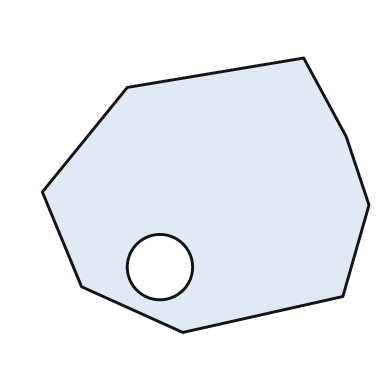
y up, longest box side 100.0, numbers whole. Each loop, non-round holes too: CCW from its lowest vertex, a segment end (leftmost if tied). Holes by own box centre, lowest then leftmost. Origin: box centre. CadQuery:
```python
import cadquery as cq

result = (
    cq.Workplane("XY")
    .moveTo(-7.0, -42.0)
    .lineTo(42.0, -31.0)
    .lineTo(50.0, -3.0)
    .lineTo(43.0, 18.0)
    .lineTo(30.0, 42.0)
    .lineTo(-24.0, 33.0)
    .lineTo(-50.0, 1.0)
    .lineTo(-38.0, -28.0)
    .close()
    .moveTo(-14.0, -22.0)
    .circle(10.0)
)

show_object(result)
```